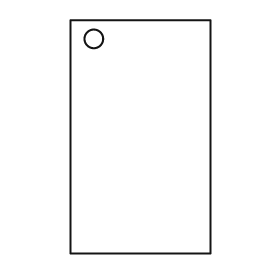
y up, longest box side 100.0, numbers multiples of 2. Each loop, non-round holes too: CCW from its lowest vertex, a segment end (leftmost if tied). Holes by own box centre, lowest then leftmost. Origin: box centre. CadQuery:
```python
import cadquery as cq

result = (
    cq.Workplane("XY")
    .moveTo(-30.0, -50.0)
    .lineTo(30.0, -50.0)
    .lineTo(30.0, 50.0)
    .lineTo(-30.0, 50.0)
    .close()
    .moveTo(-20.0, 42.0)
    .circle(4.0)
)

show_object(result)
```